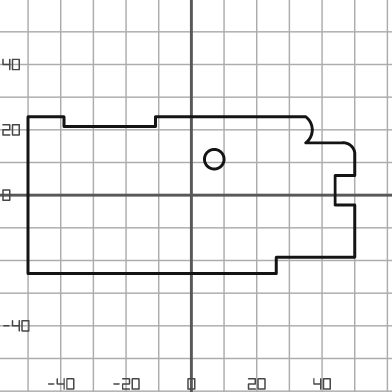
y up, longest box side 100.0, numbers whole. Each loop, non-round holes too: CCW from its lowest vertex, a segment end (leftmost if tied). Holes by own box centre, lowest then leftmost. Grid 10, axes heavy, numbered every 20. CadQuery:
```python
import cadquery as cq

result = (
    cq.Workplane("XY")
    .moveTo(-50.0, -24.0)
    .lineTo(26.0, -24.0)
    .lineTo(26.0, -19.0)
    .lineTo(50.0, -19.0)
    .lineTo(50.0, -3.0)
    .lineTo(44.0, -3.0)
    .lineTo(44.0, 6.0)
    .lineTo(50.0, 6.0)
    .lineTo(50.0, 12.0)
    .threePointArc((49.0, 15.0), (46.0, 16.0))
    .lineTo(35.0, 16.0)
    .threePointArc((37.0, 20.0), (35.0, 24.0))
    .lineTo(-11.0, 24.0)
    .lineTo(-11.0, 21.0)
    .lineTo(-39.0, 21.0)
    .lineTo(-39.0, 24.0)
    .lineTo(-50.0, 24.0)
    .close()
    .moveTo(7.0, 11.0)
    .circle(3.0)
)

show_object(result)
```